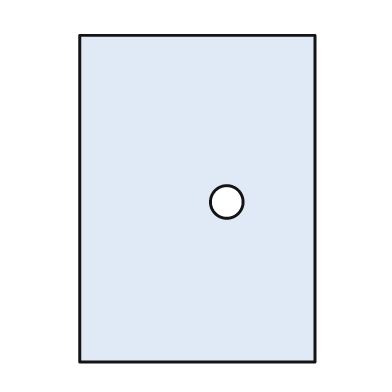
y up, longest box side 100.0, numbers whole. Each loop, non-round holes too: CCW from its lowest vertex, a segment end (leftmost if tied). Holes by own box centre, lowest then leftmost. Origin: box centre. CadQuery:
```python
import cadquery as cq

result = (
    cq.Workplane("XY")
    .moveTo(-36.0, -50.0)
    .lineTo(36.0, -50.0)
    .lineTo(36.0, 50.0)
    .lineTo(-36.0, 50.0)
    .close()
    .moveTo(9.0, -1.0)
    .circle(5.0)
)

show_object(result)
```